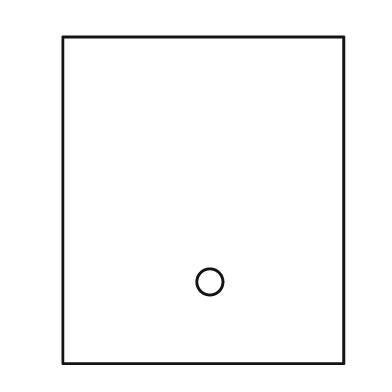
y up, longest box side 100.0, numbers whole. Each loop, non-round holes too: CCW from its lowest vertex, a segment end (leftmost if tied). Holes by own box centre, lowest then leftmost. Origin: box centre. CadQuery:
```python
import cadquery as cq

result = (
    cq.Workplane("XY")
    .moveTo(-43.0, -50.0)
    .lineTo(43.0, -50.0)
    .lineTo(43.0, 50.0)
    .lineTo(-43.0, 50.0)
    .close()
    .moveTo(2.0, -25.0)
    .circle(4.0)
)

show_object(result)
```